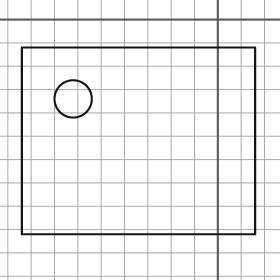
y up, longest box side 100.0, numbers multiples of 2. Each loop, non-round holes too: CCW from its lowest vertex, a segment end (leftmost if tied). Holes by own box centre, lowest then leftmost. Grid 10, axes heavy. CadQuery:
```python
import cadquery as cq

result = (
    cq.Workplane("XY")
    .moveTo(-84.0, -92.0)
    .lineTo(16.0, -92.0)
    .lineTo(16.0, -12.0)
    .lineTo(-84.0, -12.0)
    .close()
    .moveTo(-62.0, -34.0)
    .circle(8.0)
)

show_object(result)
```